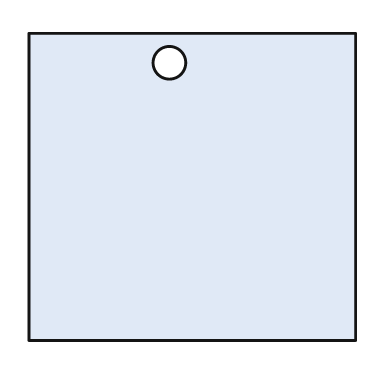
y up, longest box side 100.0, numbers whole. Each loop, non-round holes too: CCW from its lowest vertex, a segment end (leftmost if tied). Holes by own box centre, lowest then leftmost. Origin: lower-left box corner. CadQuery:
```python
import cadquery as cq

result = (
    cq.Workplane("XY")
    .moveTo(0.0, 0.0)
    .lineTo(100.0, 0.0)
    .lineTo(100.0, 94.0)
    .lineTo(0.0, 94.0)
    .close()
    .moveTo(43.0, 85.0)
    .circle(5.0)
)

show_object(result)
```